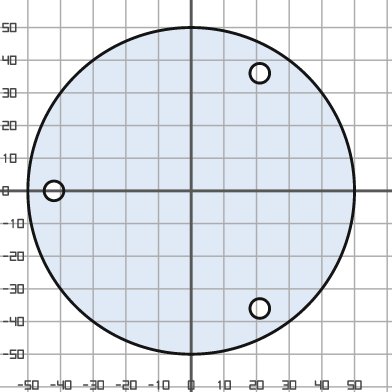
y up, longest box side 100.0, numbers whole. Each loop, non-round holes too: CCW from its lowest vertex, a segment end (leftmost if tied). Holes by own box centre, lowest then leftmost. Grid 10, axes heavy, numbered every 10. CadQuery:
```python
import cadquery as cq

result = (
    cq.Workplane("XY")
    .moveTo(0.0, 0.0)
    .circle(50.0)
    .moveTo(21.0, -36.0)
    .circle(3.0)
    .moveTo(-42.0, 0.0)
    .circle(3.0)
    .moveTo(21.0, 36.0)
    .circle(3.0)
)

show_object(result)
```